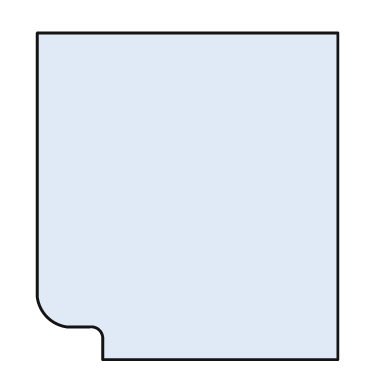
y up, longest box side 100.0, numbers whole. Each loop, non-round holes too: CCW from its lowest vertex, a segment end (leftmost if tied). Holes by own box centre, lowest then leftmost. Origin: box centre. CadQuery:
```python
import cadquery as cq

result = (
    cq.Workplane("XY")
    .moveTo(-26.0, -50.0)
    .lineTo(46.0, -50.0)
    .lineTo(46.0, 50.0)
    .lineTo(-46.0, 50.0)
    .lineTo(-46.0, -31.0)
    .threePointArc((-43.0, -37.0), (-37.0, -40.0))
    .lineTo(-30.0, -40.0)
    .threePointArc((-27.0, -41.0), (-26.0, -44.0))
    .close()
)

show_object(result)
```